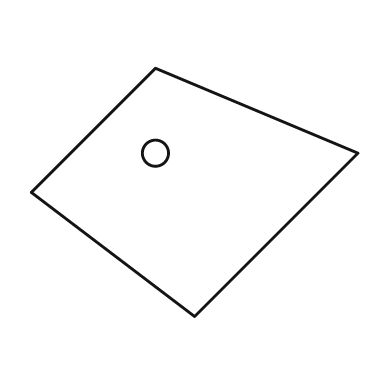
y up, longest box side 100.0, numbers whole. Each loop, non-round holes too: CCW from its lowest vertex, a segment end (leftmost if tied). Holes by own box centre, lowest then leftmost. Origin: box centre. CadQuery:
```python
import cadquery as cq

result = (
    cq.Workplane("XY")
    .moveTo(0.0, -38.0)
    .lineTo(50.0, 12.0)
    .lineTo(-12.0, 38.0)
    .lineTo(-50.0, 0.0)
    .close()
    .moveTo(-12.0, 12.0)
    .circle(4.0)
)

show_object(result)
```